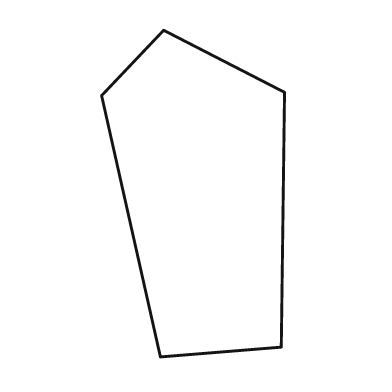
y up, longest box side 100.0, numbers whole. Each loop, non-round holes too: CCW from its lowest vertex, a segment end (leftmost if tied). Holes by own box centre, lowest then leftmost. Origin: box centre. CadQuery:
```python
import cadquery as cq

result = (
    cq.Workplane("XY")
    .moveTo(-10.0, -50.0)
    .lineTo(27.0, -47.0)
    .lineTo(28.0, 31.0)
    .lineTo(-9.0, 50.0)
    .lineTo(-28.0, 30.0)
    .close()
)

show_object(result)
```